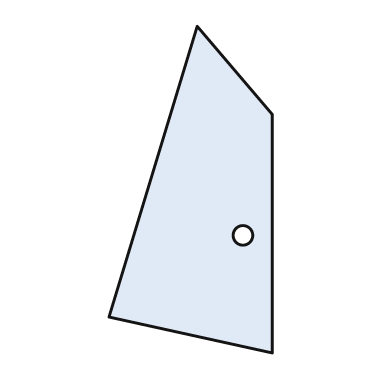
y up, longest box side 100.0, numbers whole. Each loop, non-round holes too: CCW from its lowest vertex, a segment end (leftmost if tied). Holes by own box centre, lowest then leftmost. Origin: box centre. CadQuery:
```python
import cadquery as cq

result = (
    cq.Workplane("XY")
    .moveTo(25.0, -50.0)
    .lineTo(25.0, 23.0)
    .lineTo(2.0, 50.0)
    .lineTo(-25.0, -39.0)
    .close()
    .moveTo(16.0, -14.0)
    .circle(3.0)
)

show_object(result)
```